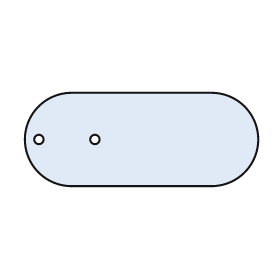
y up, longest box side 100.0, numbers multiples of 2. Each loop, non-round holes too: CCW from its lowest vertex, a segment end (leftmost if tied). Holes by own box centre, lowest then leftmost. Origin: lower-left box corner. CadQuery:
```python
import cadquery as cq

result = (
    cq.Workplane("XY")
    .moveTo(20.0, 0.0)
    .lineTo(80.0, 0.0)
    .threePointArc((100.0, 20.0), (80.0, 40.0))
    .lineTo(20.0, 40.0)
    .threePointArc((0.0, 20.0), (20.0, 0.0))
    .close()
    .moveTo(6.0, 20.0)
    .circle(2.0)
    .moveTo(30.0, 20.0)
    .circle(2.0)
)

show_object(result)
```